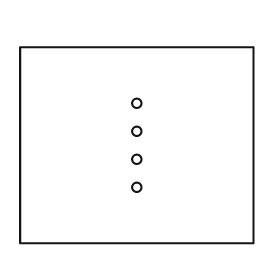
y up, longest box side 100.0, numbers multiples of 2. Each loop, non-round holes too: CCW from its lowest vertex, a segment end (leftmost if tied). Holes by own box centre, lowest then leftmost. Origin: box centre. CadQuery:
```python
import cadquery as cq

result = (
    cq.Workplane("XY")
    .moveTo(-50.0, -42.0)
    .lineTo(50.0, -42.0)
    .lineTo(50.0, 42.0)
    .lineTo(-50.0, 42.0)
    .close()
    .moveTo(0.0, -18.0)
    .circle(2.0)
    .moveTo(0.0, -6.0)
    .circle(2.0)
    .moveTo(0.0, 6.0)
    .circle(2.0)
    .moveTo(0.0, 18.0)
    .circle(2.0)
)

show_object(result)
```